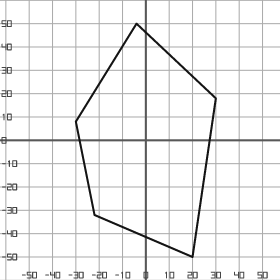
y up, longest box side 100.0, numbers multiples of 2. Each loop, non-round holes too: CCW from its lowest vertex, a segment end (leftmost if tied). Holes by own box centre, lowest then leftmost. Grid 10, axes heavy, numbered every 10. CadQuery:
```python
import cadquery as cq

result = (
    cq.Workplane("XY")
    .moveTo(20.0, -50.0)
    .lineTo(30.0, 18.0)
    .lineTo(-4.0, 50.0)
    .lineTo(-30.0, 8.0)
    .lineTo(-22.0, -32.0)
    .close()
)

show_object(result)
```